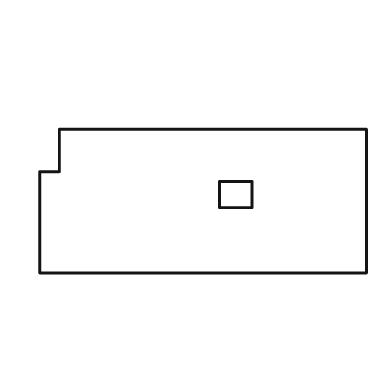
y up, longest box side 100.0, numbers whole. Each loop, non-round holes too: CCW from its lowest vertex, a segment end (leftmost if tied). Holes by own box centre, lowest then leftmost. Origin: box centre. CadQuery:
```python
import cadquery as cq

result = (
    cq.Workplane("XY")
    .moveTo(-50.0, -22.0)
    .lineTo(50.0, -22.0)
    .lineTo(50.0, 22.0)
    .lineTo(-44.0, 22.0)
    .lineTo(-44.0, 9.0)
    .lineTo(-50.0, 9.0)
    .close()
    .moveTo(5.0, -2.0)
    .lineTo(15.0, -2.0)
    .lineTo(15.0, 6.0)
    .lineTo(5.0, 6.0)
    .close()
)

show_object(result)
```